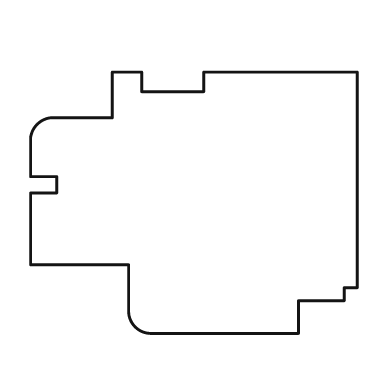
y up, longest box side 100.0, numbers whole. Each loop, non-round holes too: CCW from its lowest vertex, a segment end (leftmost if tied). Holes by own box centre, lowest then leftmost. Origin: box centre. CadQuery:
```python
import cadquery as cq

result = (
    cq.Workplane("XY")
    .moveTo(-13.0, -40.0)
    .lineTo(32.0, -40.0)
    .lineTo(32.0, -30.0)
    .lineTo(46.0, -30.0)
    .lineTo(46.0, -26.0)
    .lineTo(50.0, -26.0)
    .lineTo(50.0, 40.0)
    .lineTo(3.0, 40.0)
    .lineTo(3.0, 34.0)
    .lineTo(-16.0, 34.0)
    .lineTo(-16.0, 40.0)
    .lineTo(-25.0, 40.0)
    .lineTo(-25.0, 26.0)
    .lineTo(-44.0, 26.0)
    .threePointArc((-48.0, 24.0), (-50.0, 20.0))
    .lineTo(-50.0, 8.0)
    .lineTo(-42.0, 8.0)
    .lineTo(-42.0, 3.0)
    .lineTo(-50.0, 3.0)
    .lineTo(-50.0, -19.0)
    .lineTo(-20.0, -19.0)
    .lineTo(-20.0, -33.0)
    .threePointArc((-18.0, -38.0), (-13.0, -40.0))
    .close()
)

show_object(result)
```